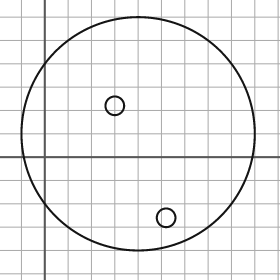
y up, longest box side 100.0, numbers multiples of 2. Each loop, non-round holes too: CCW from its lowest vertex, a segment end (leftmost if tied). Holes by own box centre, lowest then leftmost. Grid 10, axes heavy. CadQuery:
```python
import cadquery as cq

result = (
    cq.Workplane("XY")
    .moveTo(40.0, 10.0)
    .circle(50.0)
    .moveTo(52.0, -26.0)
    .circle(4.0)
    .moveTo(30.0, 22.0)
    .circle(4.0)
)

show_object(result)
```